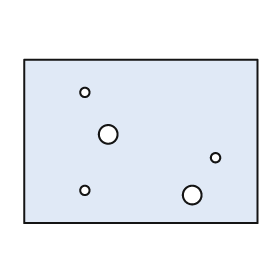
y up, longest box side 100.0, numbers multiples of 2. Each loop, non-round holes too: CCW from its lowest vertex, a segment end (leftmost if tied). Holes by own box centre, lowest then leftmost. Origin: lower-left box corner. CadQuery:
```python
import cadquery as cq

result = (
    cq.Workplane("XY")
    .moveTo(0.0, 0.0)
    .lineTo(100.0, 0.0)
    .lineTo(100.0, 70.0)
    .lineTo(0.0, 70.0)
    .close()
    .moveTo(72.0, 12.0)
    .circle(4.0)
    .moveTo(26.0, 14.0)
    .circle(2.0)
    .moveTo(82.0, 28.0)
    .circle(2.0)
    .moveTo(36.0, 38.0)
    .circle(4.0)
    .moveTo(26.0, 56.0)
    .circle(2.0)
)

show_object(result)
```